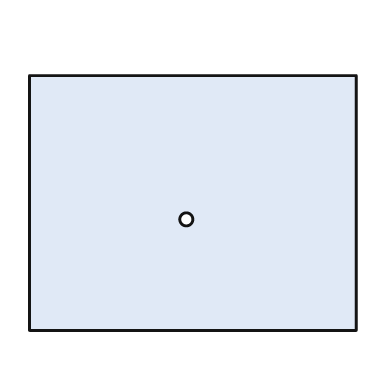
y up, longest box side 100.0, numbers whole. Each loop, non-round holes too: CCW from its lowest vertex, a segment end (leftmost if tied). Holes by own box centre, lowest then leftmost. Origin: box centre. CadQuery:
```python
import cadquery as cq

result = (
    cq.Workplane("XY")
    .moveTo(-50.0, -39.0)
    .lineTo(50.0, -39.0)
    .lineTo(50.0, 39.0)
    .lineTo(-50.0, 39.0)
    .close()
    .moveTo(-2.0, -5.0)
    .circle(2.0)
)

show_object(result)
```